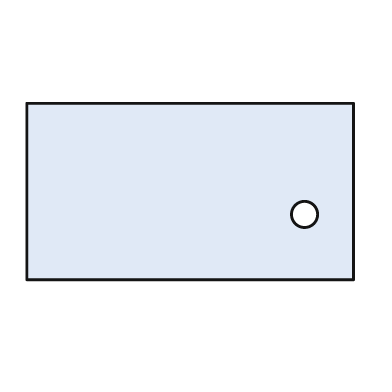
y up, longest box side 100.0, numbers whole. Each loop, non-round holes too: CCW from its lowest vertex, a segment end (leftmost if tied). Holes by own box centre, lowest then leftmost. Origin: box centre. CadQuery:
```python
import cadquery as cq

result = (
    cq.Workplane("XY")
    .moveTo(-50.0, -27.0)
    .lineTo(50.0, -27.0)
    .lineTo(50.0, 27.0)
    .lineTo(-50.0, 27.0)
    .close()
    .moveTo(35.0, -7.0)
    .circle(4.0)
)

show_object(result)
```